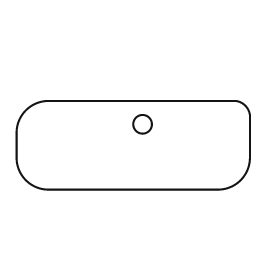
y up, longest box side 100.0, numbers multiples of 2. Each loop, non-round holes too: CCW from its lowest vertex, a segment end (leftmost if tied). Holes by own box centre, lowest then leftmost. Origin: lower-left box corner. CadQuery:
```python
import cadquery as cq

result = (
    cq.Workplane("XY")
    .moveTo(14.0, 0.0)
    .lineTo(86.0, 0.0)
    .threePointArc((96.0, 4.0), (100.0, 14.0))
    .lineTo(100.0, 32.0)
    .threePointArc((98.0, 36.0), (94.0, 38.0))
    .lineTo(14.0, 38.0)
    .threePointArc((4.0, 34.0), (0.0, 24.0))
    .lineTo(0.0, 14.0)
    .threePointArc((4.0, 4.0), (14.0, 0.0))
    .close()
    .moveTo(54.0, 28.0)
    .circle(4.0)
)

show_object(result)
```